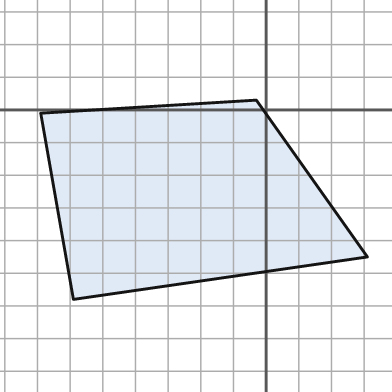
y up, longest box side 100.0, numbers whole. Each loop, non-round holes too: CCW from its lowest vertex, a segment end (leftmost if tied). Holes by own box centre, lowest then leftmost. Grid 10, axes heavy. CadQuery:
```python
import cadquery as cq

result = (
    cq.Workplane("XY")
    .moveTo(-59.0, -58.0)
    .lineTo(31.0, -45.0)
    .lineTo(-3.0, 3.0)
    .lineTo(-69.0, -1.0)
    .close()
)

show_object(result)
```